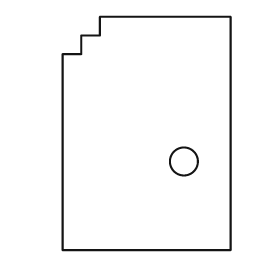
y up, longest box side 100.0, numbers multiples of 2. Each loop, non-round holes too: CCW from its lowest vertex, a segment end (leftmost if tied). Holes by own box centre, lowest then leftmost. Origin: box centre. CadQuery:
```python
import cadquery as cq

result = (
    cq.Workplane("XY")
    .moveTo(-36.0, -50.0)
    .lineTo(36.0, -50.0)
    .lineTo(36.0, 50.0)
    .lineTo(-20.0, 50.0)
    .lineTo(-20.0, 42.0)
    .lineTo(-28.0, 42.0)
    .lineTo(-28.0, 34.0)
    .lineTo(-36.0, 34.0)
    .close()
    .moveTo(16.0, -12.0)
    .circle(6.0)
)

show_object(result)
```